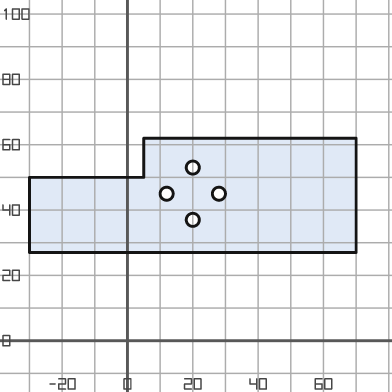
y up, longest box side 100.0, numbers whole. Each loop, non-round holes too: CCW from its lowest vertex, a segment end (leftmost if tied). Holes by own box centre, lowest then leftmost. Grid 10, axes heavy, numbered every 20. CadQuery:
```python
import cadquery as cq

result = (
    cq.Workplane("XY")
    .moveTo(-30.0, 27.0)
    .lineTo(70.0, 27.0)
    .lineTo(70.0, 62.0)
    .lineTo(5.0, 62.0)
    .lineTo(5.0, 50.0)
    .lineTo(-30.0, 50.0)
    .close()
    .moveTo(20.0, 37.0)
    .circle(2.0)
    .moveTo(12.0, 45.0)
    .circle(2.0)
    .moveTo(28.0, 45.0)
    .circle(2.0)
    .moveTo(20.0, 53.0)
    .circle(2.0)
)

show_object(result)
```